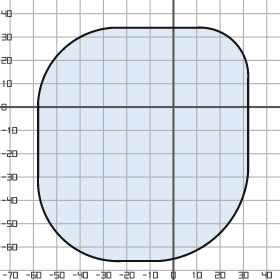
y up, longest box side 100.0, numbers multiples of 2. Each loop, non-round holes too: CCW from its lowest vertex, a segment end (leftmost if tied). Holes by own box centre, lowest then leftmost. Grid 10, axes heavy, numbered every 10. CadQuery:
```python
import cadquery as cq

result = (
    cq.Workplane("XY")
    .moveTo(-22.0, -66.0)
    .lineTo(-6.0, -66.0)
    .threePointArc((20.0, -54.0), (32.0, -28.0))
    .lineTo(32.0, 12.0)
    .threePointArc((26.0, 28.0), (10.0, 34.0))
    .lineTo(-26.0, 34.0)
    .threePointArc((-48.0, 24.0), (-58.0, 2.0))
    .lineTo(-58.0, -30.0)
    .threePointArc((-48.0, -56.0), (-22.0, -66.0))
    .close()
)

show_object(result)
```